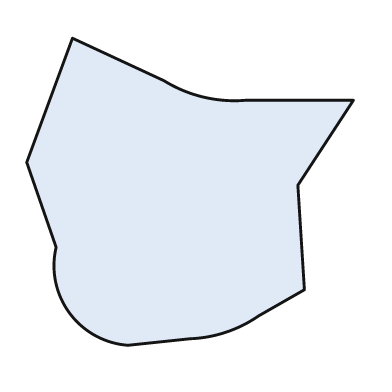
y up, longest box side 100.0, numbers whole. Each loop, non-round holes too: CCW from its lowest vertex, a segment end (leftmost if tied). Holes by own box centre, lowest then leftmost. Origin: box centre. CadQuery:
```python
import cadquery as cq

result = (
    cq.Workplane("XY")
    .moveTo(-19.0, -47.0)
    .lineTo(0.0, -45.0)
    .threePointArc((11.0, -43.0), (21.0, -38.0))
    .lineTo(35.0, -30.0)
    .lineTo(33.0, 2.0)
    .lineTo(50.0, 28.0)
    .lineTo(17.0, 28.0)
    .threePointArc((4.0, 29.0), (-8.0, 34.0))
    .lineTo(-36.0, 47.0)
    .lineTo(-50.0, 9.0)
    .lineTo(-41.0, -17.0)
    .threePointArc((-37.0, -37.0), (-19.0, -47.0))
    .close()
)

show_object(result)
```